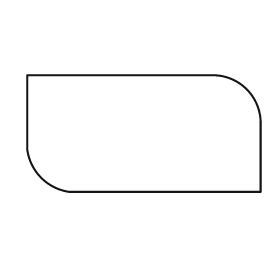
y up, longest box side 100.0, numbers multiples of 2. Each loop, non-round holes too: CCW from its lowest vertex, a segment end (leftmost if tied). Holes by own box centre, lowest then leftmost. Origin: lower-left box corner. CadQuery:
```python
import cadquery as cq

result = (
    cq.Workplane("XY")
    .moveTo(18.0, 0.0)
    .lineTo(100.0, 0.0)
    .lineTo(100.0, 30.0)
    .threePointArc((94.0, 44.0), (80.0, 50.0))
    .lineTo(0.0, 50.0)
    .lineTo(0.0, 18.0)
    .threePointArc((6.0, 6.0), (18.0, 0.0))
    .close()
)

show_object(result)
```